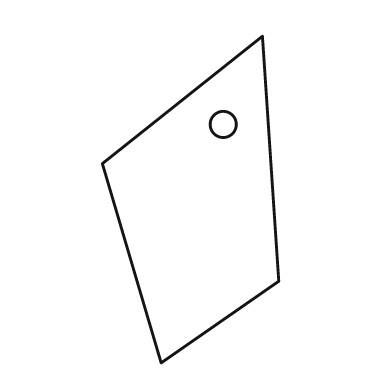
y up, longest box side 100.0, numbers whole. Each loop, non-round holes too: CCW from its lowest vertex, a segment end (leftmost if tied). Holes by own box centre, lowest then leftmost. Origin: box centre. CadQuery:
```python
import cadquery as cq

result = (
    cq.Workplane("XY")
    .moveTo(-9.0, -50.0)
    .lineTo(27.0, -25.0)
    .lineTo(22.0, 50.0)
    .lineTo(-27.0, 11.0)
    .close()
    .moveTo(10.0, 23.0)
    .circle(4.0)
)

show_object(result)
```